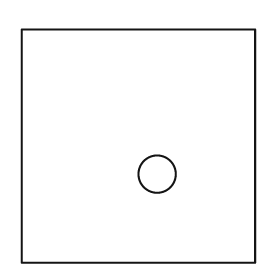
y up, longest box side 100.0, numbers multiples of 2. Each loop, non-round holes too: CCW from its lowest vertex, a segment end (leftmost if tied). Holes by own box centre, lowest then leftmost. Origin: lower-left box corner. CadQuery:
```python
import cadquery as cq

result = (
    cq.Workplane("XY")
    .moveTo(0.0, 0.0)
    .lineTo(100.0, 0.0)
    .lineTo(100.0, 100.0)
    .lineTo(0.0, 100.0)
    .close()
    .moveTo(58.0, 38.0)
    .circle(8.0)
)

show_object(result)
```